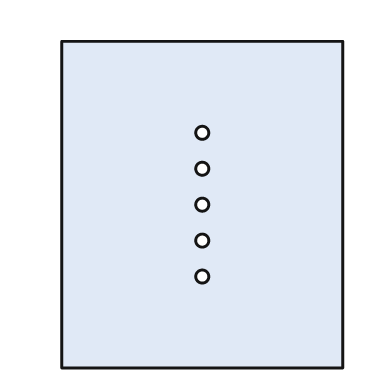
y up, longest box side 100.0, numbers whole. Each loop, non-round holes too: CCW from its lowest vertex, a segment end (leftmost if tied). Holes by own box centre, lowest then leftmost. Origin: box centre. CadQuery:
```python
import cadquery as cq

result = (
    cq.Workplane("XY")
    .moveTo(-43.0, -50.0)
    .lineTo(43.0, -50.0)
    .lineTo(43.0, 50.0)
    .lineTo(-43.0, 50.0)
    .close()
    .moveTo(0.0, -22.0)
    .circle(2.0)
    .moveTo(0.0, -11.0)
    .circle(2.0)
    .moveTo(0.0, 0.0)
    .circle(2.0)
    .moveTo(0.0, 11.0)
    .circle(2.0)
    .moveTo(0.0, 22.0)
    .circle(2.0)
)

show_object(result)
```